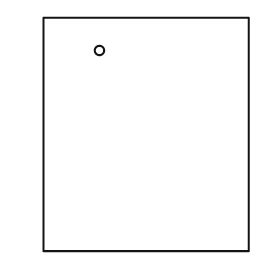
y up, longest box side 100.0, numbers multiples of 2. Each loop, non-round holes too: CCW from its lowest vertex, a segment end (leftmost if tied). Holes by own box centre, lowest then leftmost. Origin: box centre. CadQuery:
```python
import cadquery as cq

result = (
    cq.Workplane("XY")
    .moveTo(-44.0, -50.0)
    .lineTo(44.0, -50.0)
    .lineTo(44.0, 50.0)
    .lineTo(-44.0, 50.0)
    .close()
    .moveTo(-20.0, 36.0)
    .circle(2.0)
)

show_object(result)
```